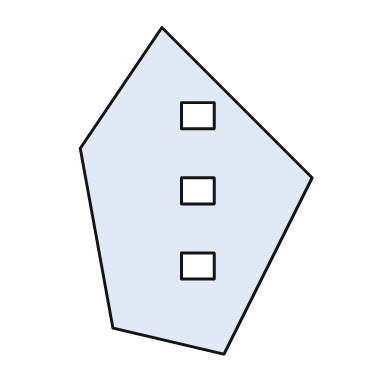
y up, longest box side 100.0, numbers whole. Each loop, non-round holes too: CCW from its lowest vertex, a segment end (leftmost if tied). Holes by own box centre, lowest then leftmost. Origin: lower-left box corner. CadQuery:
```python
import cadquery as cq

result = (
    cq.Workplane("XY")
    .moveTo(44.0, 0.0)
    .lineTo(71.0, 54.0)
    .lineTo(25.0, 100.0)
    .lineTo(0.0, 63.0)
    .lineTo(10.0, 8.0)
    .close()
    .moveTo(31.0, 23.0)
    .lineTo(41.0, 23.0)
    .lineTo(41.0, 31.0)
    .lineTo(31.0, 31.0)
    .close()
    .moveTo(31.0, 46.0)
    .lineTo(41.0, 46.0)
    .lineTo(41.0, 54.0)
    .lineTo(31.0, 54.0)
    .close()
    .moveTo(31.0, 69.0)
    .lineTo(41.0, 69.0)
    .lineTo(41.0, 77.0)
    .lineTo(31.0, 77.0)
    .close()
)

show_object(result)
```